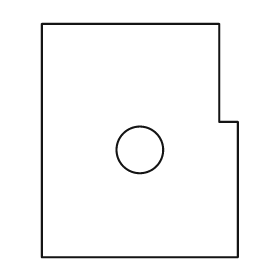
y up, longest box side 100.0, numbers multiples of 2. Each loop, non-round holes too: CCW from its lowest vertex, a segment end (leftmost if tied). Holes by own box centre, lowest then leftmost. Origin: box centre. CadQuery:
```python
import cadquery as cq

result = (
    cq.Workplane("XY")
    .moveTo(-42.0, -50.0)
    .lineTo(42.0, -50.0)
    .lineTo(42.0, 8.0)
    .lineTo(34.0, 8.0)
    .lineTo(34.0, 50.0)
    .lineTo(-42.0, 50.0)
    .close()
    .moveTo(0.0, -4.0)
    .circle(10.0)
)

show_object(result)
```